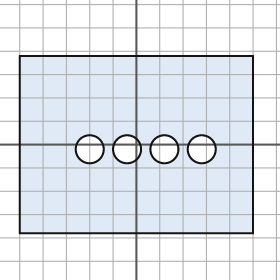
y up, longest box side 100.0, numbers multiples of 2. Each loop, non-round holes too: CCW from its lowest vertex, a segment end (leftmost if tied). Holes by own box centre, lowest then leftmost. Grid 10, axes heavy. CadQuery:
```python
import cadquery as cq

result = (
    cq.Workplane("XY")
    .moveTo(-50.0, -38.0)
    .lineTo(50.0, -38.0)
    .lineTo(50.0, 38.0)
    .lineTo(-50.0, 38.0)
    .close()
    .moveTo(-20.0, -2.0)
    .circle(6.0)
    .moveTo(-4.0, -2.0)
    .circle(6.0)
    .moveTo(12.0, -2.0)
    .circle(6.0)
    .moveTo(28.0, -2.0)
    .circle(6.0)
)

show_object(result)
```